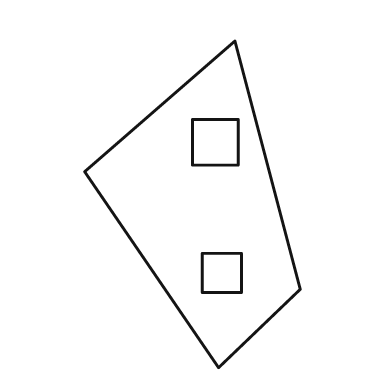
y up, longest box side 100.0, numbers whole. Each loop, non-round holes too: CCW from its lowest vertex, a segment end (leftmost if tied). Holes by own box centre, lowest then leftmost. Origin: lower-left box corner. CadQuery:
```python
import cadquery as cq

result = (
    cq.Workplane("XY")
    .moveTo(41.0, 0.0)
    .lineTo(66.0, 24.0)
    .lineTo(46.0, 100.0)
    .lineTo(0.0, 60.0)
    .close()
    .moveTo(36.0, 23.0)
    .lineTo(48.0, 23.0)
    .lineTo(48.0, 35.0)
    .lineTo(36.0, 35.0)
    .close()
    .moveTo(33.0, 62.0)
    .lineTo(47.0, 62.0)
    .lineTo(47.0, 76.0)
    .lineTo(33.0, 76.0)
    .close()
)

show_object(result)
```